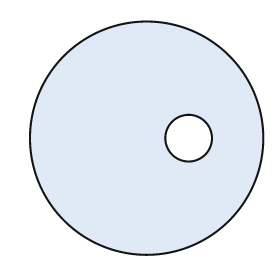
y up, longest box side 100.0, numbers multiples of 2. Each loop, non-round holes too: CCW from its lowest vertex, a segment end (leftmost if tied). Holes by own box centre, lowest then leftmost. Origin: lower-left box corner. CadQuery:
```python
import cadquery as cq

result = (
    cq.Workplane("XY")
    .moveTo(50.0, 50.0)
    .circle(50.0)
    .moveTo(68.0, 50.0)
    .circle(10.0)
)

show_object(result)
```